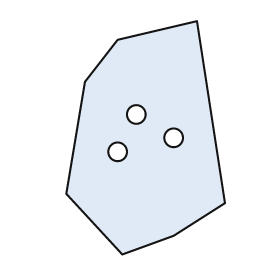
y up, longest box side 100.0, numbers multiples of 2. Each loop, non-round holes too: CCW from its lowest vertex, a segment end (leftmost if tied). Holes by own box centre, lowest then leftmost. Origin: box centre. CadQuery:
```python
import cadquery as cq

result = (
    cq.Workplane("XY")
    .moveTo(-10.0, -50.0)
    .lineTo(12.0, -42.0)
    .lineTo(34.0, -28.0)
    .lineTo(22.0, 50.0)
    .lineTo(-12.0, 42.0)
    .lineTo(-26.0, 24.0)
    .lineTo(-34.0, -24.0)
    .close()
    .moveTo(-12.0, -6.0)
    .circle(4.0)
    .moveTo(12.0, 0.0)
    .circle(4.0)
    .moveTo(-4.0, 10.0)
    .circle(4.0)
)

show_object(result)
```